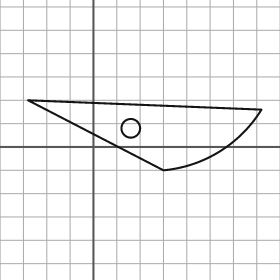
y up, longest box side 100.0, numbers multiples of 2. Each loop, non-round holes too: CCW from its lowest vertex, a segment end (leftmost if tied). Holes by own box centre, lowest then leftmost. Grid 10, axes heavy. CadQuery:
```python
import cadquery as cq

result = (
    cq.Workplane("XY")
    .moveTo(30.0, -10.0)
    .threePointArc((54.0, -2.0), (72.0, 16.0))
    .lineTo(-28.0, 20.0)
    .close()
    .moveTo(16.0, 8.0)
    .circle(4.0)
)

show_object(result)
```